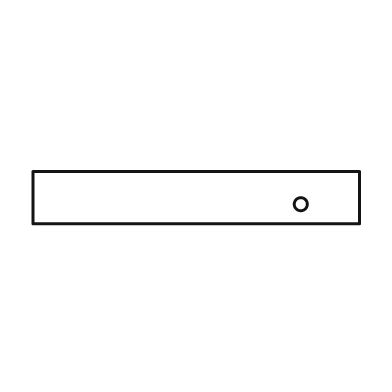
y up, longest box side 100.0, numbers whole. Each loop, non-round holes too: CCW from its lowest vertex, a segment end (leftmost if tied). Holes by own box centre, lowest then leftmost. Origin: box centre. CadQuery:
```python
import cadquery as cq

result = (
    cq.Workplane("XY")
    .moveTo(-50.0, -8.0)
    .lineTo(50.0, -8.0)
    .lineTo(50.0, 8.0)
    .lineTo(-50.0, 8.0)
    .close()
    .moveTo(32.0, -2.0)
    .circle(2.0)
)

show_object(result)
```